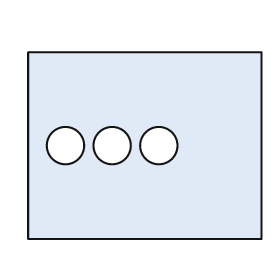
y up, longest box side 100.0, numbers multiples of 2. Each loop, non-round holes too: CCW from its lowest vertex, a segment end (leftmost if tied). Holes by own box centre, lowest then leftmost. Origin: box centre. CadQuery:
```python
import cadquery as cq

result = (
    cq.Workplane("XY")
    .moveTo(-50.0, -40.0)
    .lineTo(50.0, -40.0)
    .lineTo(50.0, 40.0)
    .lineTo(-50.0, 40.0)
    .close()
    .moveTo(-34.0, 0.0)
    .circle(8.0)
    .moveTo(-14.0, 0.0)
    .circle(8.0)
    .moveTo(6.0, 0.0)
    .circle(8.0)
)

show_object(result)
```